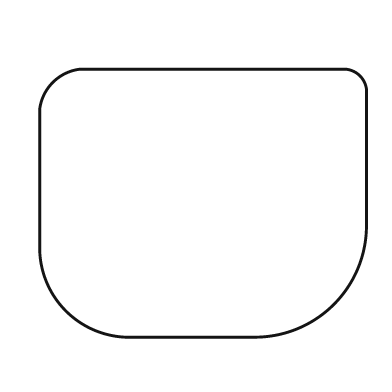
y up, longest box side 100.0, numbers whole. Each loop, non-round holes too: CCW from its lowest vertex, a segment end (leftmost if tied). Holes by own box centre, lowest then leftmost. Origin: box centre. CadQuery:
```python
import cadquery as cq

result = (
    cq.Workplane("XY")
    .moveTo(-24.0, -41.0)
    .lineTo(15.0, -41.0)
    .threePointArc((40.0, -31.0), (50.0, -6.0))
    .lineTo(50.0, 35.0)
    .threePointArc((48.0, 39.0), (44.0, 41.0))
    .lineTo(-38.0, 41.0)
    .threePointArc((-46.0, 37.0), (-50.0, 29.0))
    .lineTo(-50.0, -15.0)
    .threePointArc((-42.0, -33.0), (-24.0, -41.0))
    .close()
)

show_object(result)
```